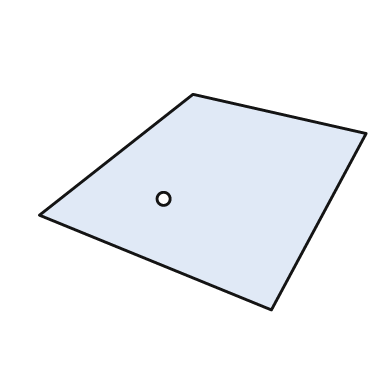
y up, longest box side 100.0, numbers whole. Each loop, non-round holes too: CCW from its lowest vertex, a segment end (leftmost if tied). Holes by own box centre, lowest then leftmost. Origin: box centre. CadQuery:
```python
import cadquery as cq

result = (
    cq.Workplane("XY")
    .moveTo(21.0, -33.0)
    .lineTo(50.0, 21.0)
    .lineTo(-3.0, 33.0)
    .lineTo(-50.0, -4.0)
    .close()
    .moveTo(-12.0, 1.0)
    .circle(2.0)
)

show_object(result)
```